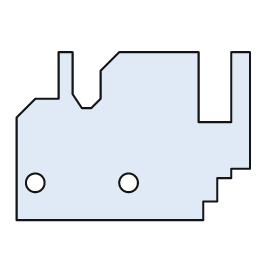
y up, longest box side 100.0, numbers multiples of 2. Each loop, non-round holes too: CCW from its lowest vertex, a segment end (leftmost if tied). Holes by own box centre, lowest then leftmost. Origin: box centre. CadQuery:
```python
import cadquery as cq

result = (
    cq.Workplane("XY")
    .moveTo(-50.0, -36.0)
    .lineTo(30.0, -36.0)
    .lineTo(30.0, -28.0)
    .lineTo(36.0, -28.0)
    .lineTo(36.0, -18.0)
    .lineTo(42.0, -18.0)
    .lineTo(42.0, -14.0)
    .lineTo(50.0, -14.0)
    .lineTo(50.0, 36.0)
    .lineTo(42.0, 36.0)
    .lineTo(42.0, 6.0)
    .lineTo(28.0, 6.0)
    .lineTo(28.0, 36.0)
    .lineTo(-6.0, 36.0)
    .lineTo(-14.0, 28.0)
    .lineTo(-14.0, 16.0)
    .lineTo(-18.0, 12.0)
    .lineTo(-22.0, 12.0)
    .lineTo(-26.0, 18.0)
    .lineTo(-26.0, 36.0)
    .lineTo(-32.0, 36.0)
    .lineTo(-32.0, 16.0)
    .lineTo(-42.0, 16.0)
    .lineTo(-50.0, 8.0)
    .close()
    .moveTo(-42.0, -20.0)
    .circle(4.0)
    .moveTo(-2.0, -20.0)
    .circle(4.0)
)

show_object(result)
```